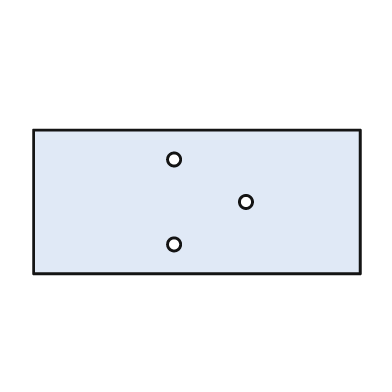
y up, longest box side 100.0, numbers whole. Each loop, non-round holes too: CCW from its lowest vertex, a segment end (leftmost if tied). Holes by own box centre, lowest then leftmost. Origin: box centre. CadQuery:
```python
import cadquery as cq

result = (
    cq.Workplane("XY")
    .moveTo(-50.0, -22.0)
    .lineTo(50.0, -22.0)
    .lineTo(50.0, 22.0)
    .lineTo(-50.0, 22.0)
    .close()
    .moveTo(-7.0, -13.0)
    .circle(2.0)
    .moveTo(15.0, 0.0)
    .circle(2.0)
    .moveTo(-7.0, 13.0)
    .circle(2.0)
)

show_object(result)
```